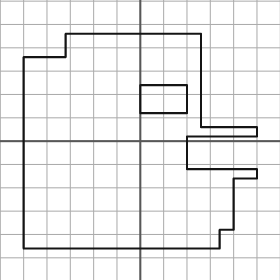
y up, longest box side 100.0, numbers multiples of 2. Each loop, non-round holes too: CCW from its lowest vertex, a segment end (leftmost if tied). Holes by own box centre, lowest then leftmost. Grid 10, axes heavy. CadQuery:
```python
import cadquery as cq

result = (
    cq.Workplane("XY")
    .moveTo(-50.0, -46.0)
    .lineTo(34.0, -46.0)
    .lineTo(34.0, -38.0)
    .lineTo(40.0, -38.0)
    .lineTo(40.0, -16.0)
    .lineTo(50.0, -16.0)
    .lineTo(50.0, -12.0)
    .lineTo(20.0, -12.0)
    .lineTo(20.0, 2.0)
    .lineTo(50.0, 2.0)
    .lineTo(50.0, 6.0)
    .lineTo(26.0, 6.0)
    .lineTo(26.0, 46.0)
    .lineTo(-32.0, 46.0)
    .lineTo(-32.0, 36.0)
    .lineTo(-50.0, 36.0)
    .close()
    .moveTo(0.0, 12.0)
    .lineTo(20.0, 12.0)
    .lineTo(20.0, 24.0)
    .lineTo(0.0, 24.0)
    .close()
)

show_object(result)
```